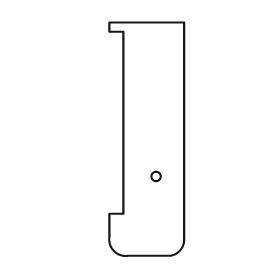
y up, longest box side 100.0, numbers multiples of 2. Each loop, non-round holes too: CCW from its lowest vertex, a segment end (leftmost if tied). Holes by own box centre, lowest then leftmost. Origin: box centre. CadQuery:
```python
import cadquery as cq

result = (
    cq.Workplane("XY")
    .moveTo(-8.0, -50.0)
    .lineTo(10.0, -50.0)
    .threePointArc((14.0, -48.0), (16.0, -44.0))
    .lineTo(16.0, 50.0)
    .lineTo(-16.0, 50.0)
    .lineTo(-16.0, 46.0)
    .lineTo(-10.0, 46.0)
    .lineTo(-10.0, -32.0)
    .lineTo(-16.0, -32.0)
    .lineTo(-16.0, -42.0)
    .threePointArc((-14.0, -48.0), (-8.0, -50.0))
    .close()
    .moveTo(4.0, -16.0)
    .circle(2.0)
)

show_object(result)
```